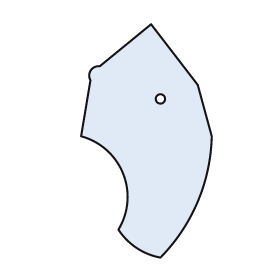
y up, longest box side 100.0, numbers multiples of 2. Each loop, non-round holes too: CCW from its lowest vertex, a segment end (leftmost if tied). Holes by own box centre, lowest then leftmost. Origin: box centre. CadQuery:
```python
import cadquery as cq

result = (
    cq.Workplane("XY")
    .moveTo(6.0, -50.0)
    .threePointArc((22.0, -26.0), (28.0, 2.0))
    .lineTo(22.0, 24.0)
    .lineTo(2.0, 50.0)
    .lineTo(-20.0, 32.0)
    .threePointArc((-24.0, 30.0), (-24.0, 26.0))
    .lineTo(-28.0, 2.0)
    .threePointArc((-10.0, -14.0), (-12.0, -38.0))
    .threePointArc((-4.0, -46.0), (6.0, -50.0))
    .close()
    .moveTo(6.0, 18.0)
    .circle(2.0)
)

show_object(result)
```